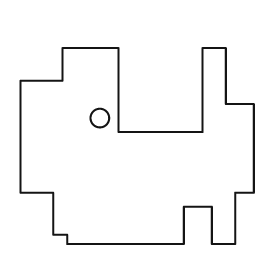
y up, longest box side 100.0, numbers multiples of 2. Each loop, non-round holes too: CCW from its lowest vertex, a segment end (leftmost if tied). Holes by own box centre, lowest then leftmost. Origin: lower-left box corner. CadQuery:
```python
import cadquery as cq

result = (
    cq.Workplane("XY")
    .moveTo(20.0, 0.0)
    .lineTo(70.0, 0.0)
    .lineTo(70.0, 16.0)
    .lineTo(82.0, 16.0)
    .lineTo(82.0, 0.0)
    .lineTo(92.0, 0.0)
    .lineTo(92.0, 22.0)
    .lineTo(100.0, 22.0)
    .lineTo(100.0, 60.0)
    .lineTo(88.0, 60.0)
    .lineTo(88.0, 84.0)
    .lineTo(78.0, 84.0)
    .lineTo(78.0, 48.0)
    .lineTo(42.0, 48.0)
    .lineTo(42.0, 84.0)
    .lineTo(18.0, 84.0)
    .lineTo(18.0, 70.0)
    .lineTo(0.0, 70.0)
    .lineTo(0.0, 22.0)
    .lineTo(14.0, 22.0)
    .lineTo(14.0, 4.0)
    .lineTo(20.0, 4.0)
    .close()
    .moveTo(34.0, 54.0)
    .circle(4.0)
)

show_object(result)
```